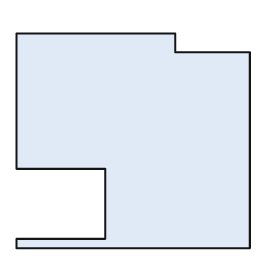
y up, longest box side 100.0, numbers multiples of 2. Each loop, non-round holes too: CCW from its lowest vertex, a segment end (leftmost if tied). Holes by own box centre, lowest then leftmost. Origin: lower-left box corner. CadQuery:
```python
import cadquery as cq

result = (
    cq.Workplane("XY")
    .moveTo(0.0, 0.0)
    .lineTo(100.0, 0.0)
    .lineTo(100.0, 84.0)
    .lineTo(68.0, 84.0)
    .lineTo(68.0, 92.0)
    .lineTo(0.0, 92.0)
    .lineTo(0.0, 34.0)
    .lineTo(38.0, 34.0)
    .lineTo(38.0, 4.0)
    .lineTo(0.0, 4.0)
    .close()
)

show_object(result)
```